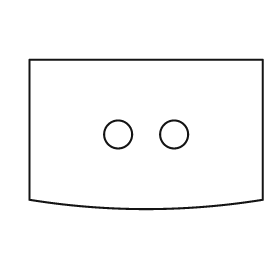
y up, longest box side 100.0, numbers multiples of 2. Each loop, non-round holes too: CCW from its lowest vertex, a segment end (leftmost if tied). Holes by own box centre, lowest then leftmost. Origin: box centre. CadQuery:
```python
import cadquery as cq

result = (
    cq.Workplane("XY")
    .moveTo(-50.0, -28.0)
    .threePointArc((0.0, -32.0), (50.0, -28.0))
    .lineTo(50.0, 32.0)
    .lineTo(-50.0, 32.0)
    .close()
    .moveTo(-12.0, 0.0)
    .circle(6.0)
    .moveTo(12.0, 0.0)
    .circle(6.0)
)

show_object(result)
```